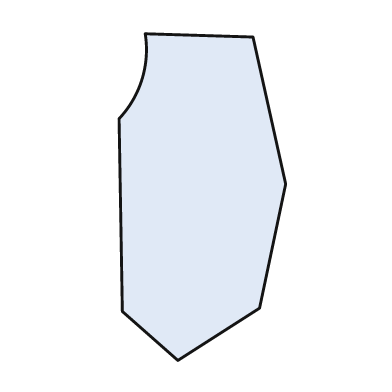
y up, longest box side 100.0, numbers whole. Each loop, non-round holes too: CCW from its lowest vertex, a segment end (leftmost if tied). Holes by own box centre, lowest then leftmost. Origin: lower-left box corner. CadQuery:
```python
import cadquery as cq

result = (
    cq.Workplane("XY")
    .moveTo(18.0, 0.0)
    .lineTo(43.0, 16.0)
    .lineTo(51.0, 54.0)
    .lineTo(41.0, 99.0)
    .lineTo(8.0, 100.0)
    .threePointArc((7.0, 86.0), (0.0, 74.0))
    .lineTo(1.0, 15.0)
    .close()
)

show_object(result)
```